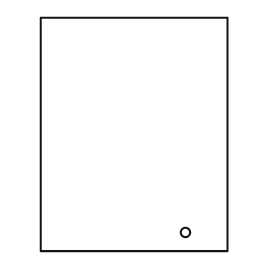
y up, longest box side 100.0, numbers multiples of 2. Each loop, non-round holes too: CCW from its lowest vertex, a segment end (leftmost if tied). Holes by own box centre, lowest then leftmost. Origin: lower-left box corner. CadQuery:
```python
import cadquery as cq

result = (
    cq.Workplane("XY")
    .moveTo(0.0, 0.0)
    .lineTo(80.0, 0.0)
    .lineTo(80.0, 100.0)
    .lineTo(0.0, 100.0)
    .close()
    .moveTo(62.0, 8.0)
    .circle(2.0)
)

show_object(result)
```